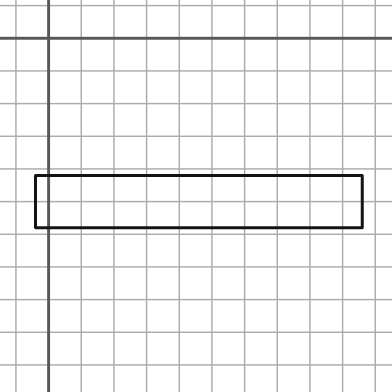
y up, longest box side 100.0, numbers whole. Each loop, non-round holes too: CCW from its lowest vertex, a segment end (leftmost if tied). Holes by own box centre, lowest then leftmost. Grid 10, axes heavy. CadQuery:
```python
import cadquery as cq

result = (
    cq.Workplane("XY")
    .moveTo(-4.0, -58.0)
    .lineTo(96.0, -58.0)
    .lineTo(96.0, -42.0)
    .lineTo(-4.0, -42.0)
    .close()
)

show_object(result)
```